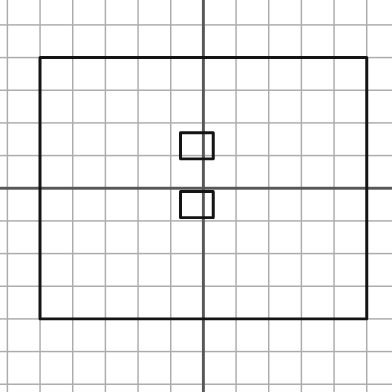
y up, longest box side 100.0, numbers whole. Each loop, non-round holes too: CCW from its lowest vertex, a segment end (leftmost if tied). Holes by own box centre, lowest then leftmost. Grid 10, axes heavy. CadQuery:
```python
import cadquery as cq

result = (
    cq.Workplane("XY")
    .moveTo(-50.0, -40.0)
    .lineTo(50.0, -40.0)
    .lineTo(50.0, 40.0)
    .lineTo(-50.0, 40.0)
    .close()
    .moveTo(-7.0, -9.0)
    .lineTo(3.0, -9.0)
    .lineTo(3.0, -1.0)
    .lineTo(-7.0, -1.0)
    .close()
    .moveTo(-7.0, 9.0)
    .lineTo(3.0, 9.0)
    .lineTo(3.0, 17.0)
    .lineTo(-7.0, 17.0)
    .close()
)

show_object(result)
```